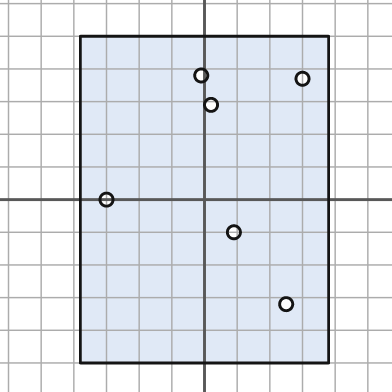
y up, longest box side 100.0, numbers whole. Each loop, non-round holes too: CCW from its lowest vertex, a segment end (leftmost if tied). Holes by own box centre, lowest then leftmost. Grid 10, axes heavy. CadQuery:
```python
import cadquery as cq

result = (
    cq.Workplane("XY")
    .moveTo(-38.0, -50.0)
    .lineTo(38.0, -50.0)
    .lineTo(38.0, 50.0)
    .lineTo(-38.0, 50.0)
    .close()
    .moveTo(25.0, -32.0)
    .circle(2.0)
    .moveTo(9.0, -10.0)
    .circle(2.0)
    .moveTo(-30.0, 0.0)
    .circle(2.0)
    .moveTo(2.0, 29.0)
    .circle(2.0)
    .moveTo(30.0, 37.0)
    .circle(2.0)
    .moveTo(-1.0, 38.0)
    .circle(2.0)
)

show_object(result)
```